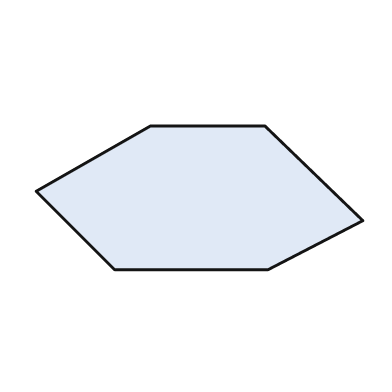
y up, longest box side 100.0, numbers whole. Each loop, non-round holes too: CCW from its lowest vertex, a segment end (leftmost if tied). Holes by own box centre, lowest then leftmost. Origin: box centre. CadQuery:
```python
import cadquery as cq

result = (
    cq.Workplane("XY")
    .moveTo(-26.0, -22.0)
    .lineTo(21.0, -22.0)
    .lineTo(50.0, -7.0)
    .lineTo(20.0, 22.0)
    .lineTo(-15.0, 22.0)
    .lineTo(-50.0, 2.0)
    .close()
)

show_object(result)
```